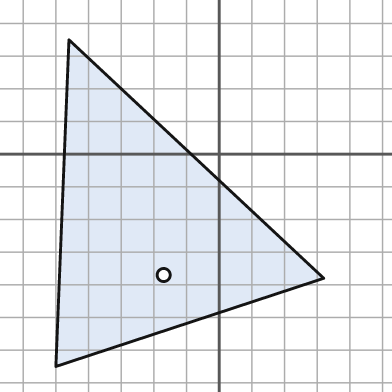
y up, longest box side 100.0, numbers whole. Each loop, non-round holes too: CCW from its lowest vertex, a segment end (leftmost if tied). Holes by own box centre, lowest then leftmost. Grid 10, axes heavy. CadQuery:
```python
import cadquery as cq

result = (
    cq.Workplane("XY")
    .moveTo(-50.0, -65.0)
    .lineTo(32.0, -38.0)
    .lineTo(-46.0, 35.0)
    .close()
    .moveTo(-17.0, -37.0)
    .circle(2.0)
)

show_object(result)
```